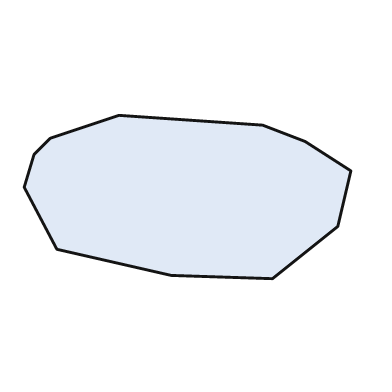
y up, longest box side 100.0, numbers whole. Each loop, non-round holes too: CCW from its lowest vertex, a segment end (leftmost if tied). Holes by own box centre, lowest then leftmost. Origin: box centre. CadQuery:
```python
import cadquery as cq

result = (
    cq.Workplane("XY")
    .moveTo(26.0, -25.0)
    .lineTo(46.0, -9.0)
    .lineTo(50.0, 8.0)
    .lineTo(36.0, 17.0)
    .lineTo(23.0, 22.0)
    .lineTo(-21.0, 25.0)
    .lineTo(-42.0, 18.0)
    .lineTo(-47.0, 13.0)
    .lineTo(-50.0, 3.0)
    .lineTo(-40.0, -16.0)
    .lineTo(-5.0, -24.0)
    .close()
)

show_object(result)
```